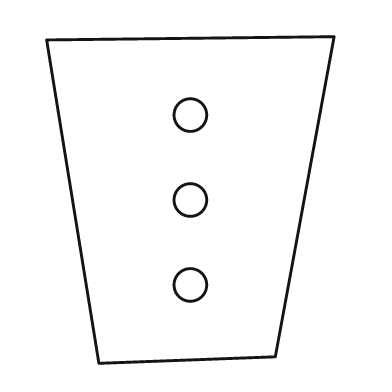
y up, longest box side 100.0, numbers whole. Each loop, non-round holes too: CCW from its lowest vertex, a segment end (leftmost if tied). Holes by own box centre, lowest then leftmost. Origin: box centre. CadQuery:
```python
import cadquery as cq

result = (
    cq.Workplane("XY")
    .moveTo(-28.0, -50.0)
    .lineTo(26.0, -48.0)
    .lineTo(44.0, 50.0)
    .lineTo(-44.0, 49.0)
    .close()
    .moveTo(0.0, -26.0)
    .circle(5.0)
    .moveTo(0.0, 0.0)
    .circle(5.0)
    .moveTo(0.0, 26.0)
    .circle(5.0)
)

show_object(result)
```